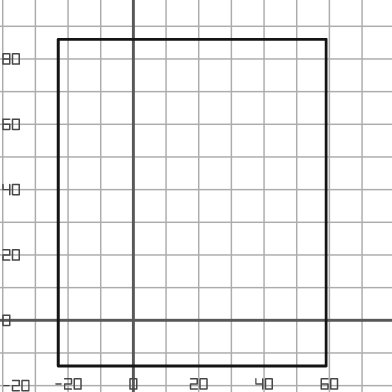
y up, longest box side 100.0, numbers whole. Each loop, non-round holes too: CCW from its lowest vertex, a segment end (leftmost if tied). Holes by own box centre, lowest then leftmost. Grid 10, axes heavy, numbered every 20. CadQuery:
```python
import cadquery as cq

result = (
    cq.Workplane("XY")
    .moveTo(-23.0, -14.0)
    .lineTo(59.0, -14.0)
    .lineTo(59.0, 86.0)
    .lineTo(-23.0, 86.0)
    .close()
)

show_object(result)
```